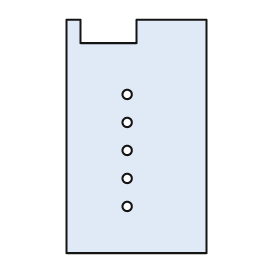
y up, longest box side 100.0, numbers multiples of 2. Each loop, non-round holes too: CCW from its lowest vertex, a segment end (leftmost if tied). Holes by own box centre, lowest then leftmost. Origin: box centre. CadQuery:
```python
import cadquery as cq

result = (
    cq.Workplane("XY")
    .moveTo(-30.0, -50.0)
    .lineTo(30.0, -50.0)
    .lineTo(30.0, 50.0)
    .lineTo(0.0, 50.0)
    .lineTo(0.0, 40.0)
    .lineTo(-24.0, 40.0)
    .lineTo(-24.0, 50.0)
    .lineTo(-30.0, 50.0)
    .close()
    .moveTo(-4.0, -30.0)
    .circle(2.0)
    .moveTo(-4.0, -18.0)
    .circle(2.0)
    .moveTo(-4.0, -6.0)
    .circle(2.0)
    .moveTo(-4.0, 6.0)
    .circle(2.0)
    .moveTo(-4.0, 18.0)
    .circle(2.0)
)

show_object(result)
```